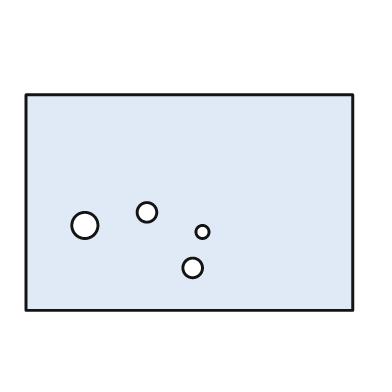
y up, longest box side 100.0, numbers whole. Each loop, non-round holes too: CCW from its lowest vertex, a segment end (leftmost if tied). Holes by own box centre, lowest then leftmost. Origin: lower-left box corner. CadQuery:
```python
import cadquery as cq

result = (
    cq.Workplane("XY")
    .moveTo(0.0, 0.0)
    .lineTo(100.0, 0.0)
    .lineTo(100.0, 66.0)
    .lineTo(0.0, 66.0)
    .close()
    .moveTo(51.0, 13.0)
    .circle(3.0)
    .moveTo(54.0, 24.0)
    .circle(2.0)
    .moveTo(18.0, 26.0)
    .circle(4.0)
    .moveTo(37.0, 30.0)
    .circle(3.0)
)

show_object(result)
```